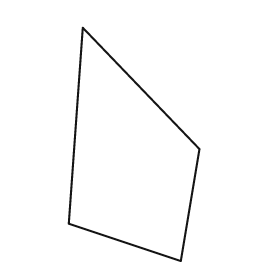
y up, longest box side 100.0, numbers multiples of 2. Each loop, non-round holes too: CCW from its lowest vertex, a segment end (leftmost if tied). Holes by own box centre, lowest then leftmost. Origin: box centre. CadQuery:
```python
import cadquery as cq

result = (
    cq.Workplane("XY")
    .moveTo(20.0, -50.0)
    .lineTo(28.0, -2.0)
    .lineTo(-22.0, 50.0)
    .lineTo(-28.0, -34.0)
    .close()
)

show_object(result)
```